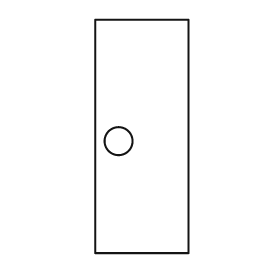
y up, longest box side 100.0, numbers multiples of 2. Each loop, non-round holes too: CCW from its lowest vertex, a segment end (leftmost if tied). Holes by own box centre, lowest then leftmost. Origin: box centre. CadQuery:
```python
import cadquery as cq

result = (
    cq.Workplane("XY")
    .moveTo(-20.0, -50.0)
    .lineTo(20.0, -50.0)
    .lineTo(20.0, 50.0)
    .lineTo(-20.0, 50.0)
    .close()
    .moveTo(-10.0, -2.0)
    .circle(6.0)
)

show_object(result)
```